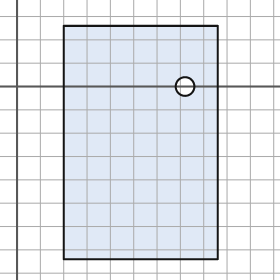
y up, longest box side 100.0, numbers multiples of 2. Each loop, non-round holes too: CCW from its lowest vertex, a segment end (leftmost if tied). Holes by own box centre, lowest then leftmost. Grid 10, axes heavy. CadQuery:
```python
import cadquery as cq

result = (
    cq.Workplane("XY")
    .moveTo(20.0, -74.0)
    .lineTo(86.0, -74.0)
    .lineTo(86.0, 26.0)
    .lineTo(20.0, 26.0)
    .close()
    .moveTo(72.0, 0.0)
    .circle(4.0)
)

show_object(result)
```